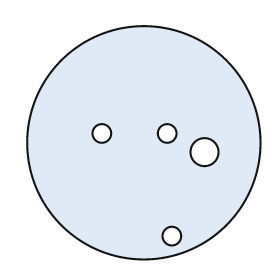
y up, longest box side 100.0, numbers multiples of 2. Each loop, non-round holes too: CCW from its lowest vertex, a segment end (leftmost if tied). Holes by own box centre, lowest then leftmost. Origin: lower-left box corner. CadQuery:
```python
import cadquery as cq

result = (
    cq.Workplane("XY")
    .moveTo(50.0, 50.0)
    .circle(50.0)
    .moveTo(62.0, 10.0)
    .circle(4.0)
    .moveTo(76.0, 46.0)
    .circle(6.0)
    .moveTo(32.0, 54.0)
    .circle(4.0)
    .moveTo(60.0, 54.0)
    .circle(4.0)
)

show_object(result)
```